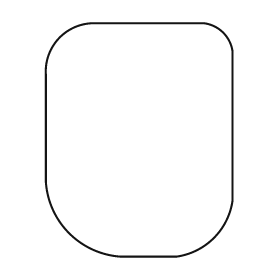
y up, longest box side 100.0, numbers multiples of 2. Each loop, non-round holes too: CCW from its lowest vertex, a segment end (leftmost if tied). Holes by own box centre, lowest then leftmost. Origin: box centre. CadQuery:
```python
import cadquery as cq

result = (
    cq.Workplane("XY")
    .moveTo(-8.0, -50.0)
    .lineTo(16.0, -50.0)
    .threePointArc((32.0, -42.0), (40.0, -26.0))
    .lineTo(40.0, 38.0)
    .threePointArc((36.0, 46.0), (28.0, 50.0))
    .lineTo(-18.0, 50.0)
    .threePointArc((-34.0, 44.0), (-40.0, 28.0))
    .lineTo(-40.0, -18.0)
    .threePointArc((-30.0, -40.0), (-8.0, -50.0))
    .close()
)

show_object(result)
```